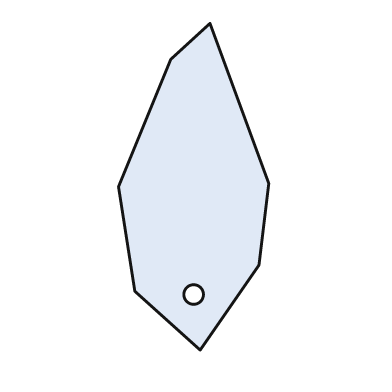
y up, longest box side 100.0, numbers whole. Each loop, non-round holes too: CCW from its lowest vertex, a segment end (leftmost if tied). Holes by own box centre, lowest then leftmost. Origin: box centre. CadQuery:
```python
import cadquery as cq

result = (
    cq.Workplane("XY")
    .moveTo(2.0, -50.0)
    .lineTo(20.0, -24.0)
    .lineTo(23.0, 1.0)
    .lineTo(5.0, 50.0)
    .lineTo(-7.0, 39.0)
    .lineTo(-23.0, 0.0)
    .lineTo(-18.0, -32.0)
    .close()
    .moveTo(0.0, -33.0)
    .circle(3.0)
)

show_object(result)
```